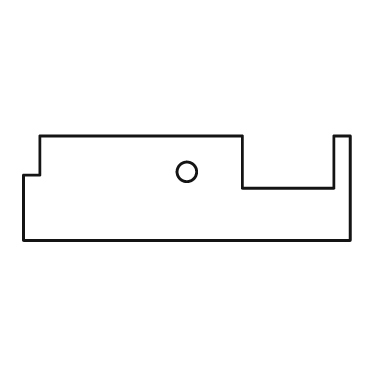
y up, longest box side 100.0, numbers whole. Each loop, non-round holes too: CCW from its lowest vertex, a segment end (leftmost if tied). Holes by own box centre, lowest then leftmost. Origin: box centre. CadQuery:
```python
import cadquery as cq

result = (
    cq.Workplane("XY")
    .moveTo(-50.0, -16.0)
    .lineTo(50.0, -16.0)
    .lineTo(50.0, 16.0)
    .lineTo(45.0, 16.0)
    .lineTo(45.0, 0.0)
    .lineTo(17.0, 0.0)
    .lineTo(17.0, 16.0)
    .lineTo(-45.0, 16.0)
    .lineTo(-45.0, 4.0)
    .lineTo(-50.0, 4.0)
    .close()
    .moveTo(0.0, 5.0)
    .circle(3.0)
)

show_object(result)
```